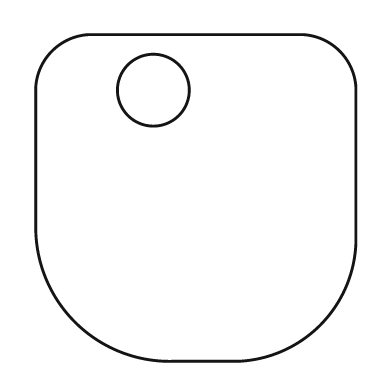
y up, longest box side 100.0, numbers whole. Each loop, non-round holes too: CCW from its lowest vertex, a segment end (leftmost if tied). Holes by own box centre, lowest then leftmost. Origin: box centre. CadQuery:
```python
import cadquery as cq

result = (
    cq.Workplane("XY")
    .moveTo(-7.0, -50.0)
    .lineTo(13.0, -50.0)
    .threePointArc((38.0, -39.0), (49.0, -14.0))
    .lineTo(49.0, 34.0)
    .threePointArc((44.0, 45.0), (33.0, 50.0))
    .lineTo(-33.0, 50.0)
    .threePointArc((-44.0, 45.0), (-49.0, 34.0))
    .lineTo(-49.0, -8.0)
    .threePointArc((-37.0, -38.0), (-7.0, -50.0))
    .close()
    .moveTo(-13.0, 33.0)
    .circle(11.0)
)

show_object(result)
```